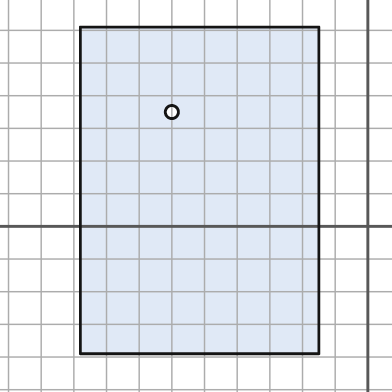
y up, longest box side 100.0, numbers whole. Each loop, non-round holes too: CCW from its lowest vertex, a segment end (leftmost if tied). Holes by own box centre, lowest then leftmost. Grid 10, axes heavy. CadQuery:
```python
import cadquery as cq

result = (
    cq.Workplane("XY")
    .moveTo(-88.0, -39.0)
    .lineTo(-15.0, -39.0)
    .lineTo(-15.0, 61.0)
    .lineTo(-88.0, 61.0)
    .close()
    .moveTo(-60.0, 35.0)
    .circle(2.0)
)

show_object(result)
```